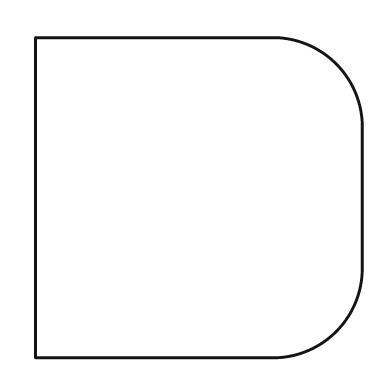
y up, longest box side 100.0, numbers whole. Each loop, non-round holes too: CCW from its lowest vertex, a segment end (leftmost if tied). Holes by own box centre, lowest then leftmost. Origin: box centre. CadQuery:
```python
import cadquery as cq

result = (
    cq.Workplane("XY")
    .moveTo(-50.0, -49.0)
    .lineTo(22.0, -49.0)
    .threePointArc((42.0, -41.0), (50.0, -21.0))
    .lineTo(50.0, 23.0)
    .threePointArc((42.0, 41.0), (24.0, 49.0))
    .lineTo(-50.0, 49.0)
    .close()
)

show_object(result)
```